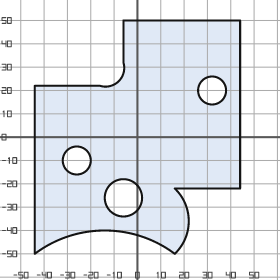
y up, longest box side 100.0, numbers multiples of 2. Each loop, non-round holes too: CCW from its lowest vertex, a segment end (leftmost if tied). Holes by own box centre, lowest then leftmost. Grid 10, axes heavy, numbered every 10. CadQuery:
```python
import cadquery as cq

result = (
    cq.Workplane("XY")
    .moveTo(-44.0, -50.0)
    .threePointArc((-14.0, -40.0), (16.0, -50.0))
    .threePointArc((22.0, -36.0), (16.0, -22.0))
    .lineTo(44.0, -22.0)
    .lineTo(44.0, 50.0)
    .lineTo(-6.0, 50.0)
    .lineTo(-6.0, 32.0)
    .threePointArc((-8.0, 24.0), (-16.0, 22.0))
    .lineTo(-44.0, 22.0)
    .close()
    .moveTo(-6.0, -26.0)
    .circle(8.0)
    .moveTo(-26.0, -10.0)
    .circle(6.0)
    .moveTo(32.0, 20.0)
    .circle(6.0)
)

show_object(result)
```